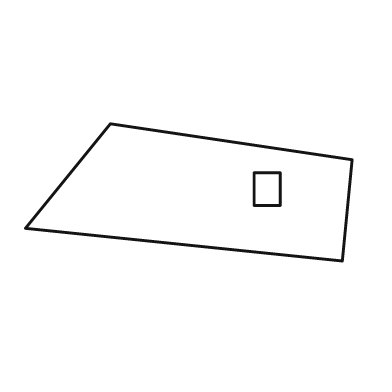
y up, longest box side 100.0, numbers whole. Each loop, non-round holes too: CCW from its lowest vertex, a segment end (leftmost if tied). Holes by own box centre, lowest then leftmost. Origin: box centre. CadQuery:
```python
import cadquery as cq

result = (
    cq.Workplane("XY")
    .moveTo(47.0, -21.0)
    .lineTo(50.0, 10.0)
    .lineTo(-24.0, 21.0)
    .lineTo(-50.0, -11.0)
    .close()
    .moveTo(20.0, -4.0)
    .lineTo(28.0, -4.0)
    .lineTo(28.0, 6.0)
    .lineTo(20.0, 6.0)
    .close()
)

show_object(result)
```